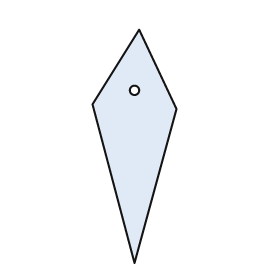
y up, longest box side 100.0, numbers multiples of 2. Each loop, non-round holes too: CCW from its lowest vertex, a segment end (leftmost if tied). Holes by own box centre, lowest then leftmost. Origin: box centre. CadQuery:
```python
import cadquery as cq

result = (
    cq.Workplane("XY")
    .moveTo(0.0, -50.0)
    .lineTo(18.0, 16.0)
    .lineTo(2.0, 50.0)
    .lineTo(-18.0, 18.0)
    .close()
    .moveTo(0.0, 24.0)
    .circle(2.0)
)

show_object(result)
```